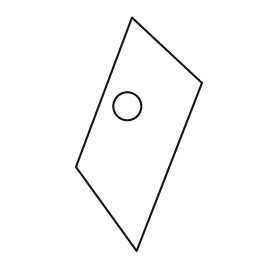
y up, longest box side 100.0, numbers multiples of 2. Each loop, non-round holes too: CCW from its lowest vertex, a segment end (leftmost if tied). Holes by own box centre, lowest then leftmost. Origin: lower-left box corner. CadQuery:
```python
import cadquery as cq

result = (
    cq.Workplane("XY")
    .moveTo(26.0, 0.0)
    .lineTo(54.0, 72.0)
    .lineTo(24.0, 100.0)
    .lineTo(0.0, 36.0)
    .close()
    .moveTo(22.0, 62.0)
    .circle(6.0)
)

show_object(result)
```